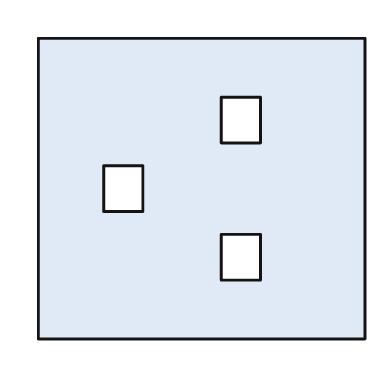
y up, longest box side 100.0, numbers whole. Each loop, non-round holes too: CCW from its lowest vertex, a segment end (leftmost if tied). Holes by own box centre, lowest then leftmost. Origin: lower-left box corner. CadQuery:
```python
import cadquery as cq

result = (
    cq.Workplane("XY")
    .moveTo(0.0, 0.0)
    .lineTo(100.0, 0.0)
    .lineTo(100.0, 92.0)
    .lineTo(0.0, 92.0)
    .close()
    .moveTo(56.0, 18.0)
    .lineTo(68.0, 18.0)
    .lineTo(68.0, 32.0)
    .lineTo(56.0, 32.0)
    .close()
    .moveTo(20.0, 39.0)
    .lineTo(32.0, 39.0)
    .lineTo(32.0, 53.0)
    .lineTo(20.0, 53.0)
    .close()
    .moveTo(56.0, 60.0)
    .lineTo(68.0, 60.0)
    .lineTo(68.0, 74.0)
    .lineTo(56.0, 74.0)
    .close()
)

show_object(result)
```